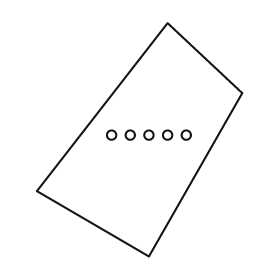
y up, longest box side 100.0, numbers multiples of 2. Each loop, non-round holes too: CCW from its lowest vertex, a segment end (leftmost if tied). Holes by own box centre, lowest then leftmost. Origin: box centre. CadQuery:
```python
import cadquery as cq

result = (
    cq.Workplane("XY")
    .moveTo(4.0, -50.0)
    .lineTo(44.0, 20.0)
    .lineTo(12.0, 50.0)
    .lineTo(-44.0, -22.0)
    .close()
    .moveTo(-12.0, 2.0)
    .circle(2.0)
    .moveTo(-4.0, 2.0)
    .circle(2.0)
    .moveTo(4.0, 2.0)
    .circle(2.0)
    .moveTo(12.0, 2.0)
    .circle(2.0)
    .moveTo(20.0, 2.0)
    .circle(2.0)
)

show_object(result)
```